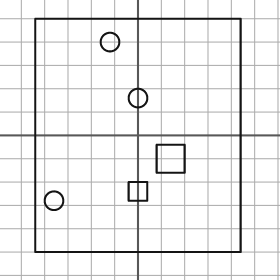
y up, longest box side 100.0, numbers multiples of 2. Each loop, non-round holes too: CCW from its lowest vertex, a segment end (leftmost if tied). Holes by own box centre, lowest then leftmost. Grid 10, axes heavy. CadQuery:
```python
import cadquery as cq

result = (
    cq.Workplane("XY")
    .moveTo(-44.0, -50.0)
    .lineTo(44.0, -50.0)
    .lineTo(44.0, 50.0)
    .lineTo(-44.0, 50.0)
    .close()
    .moveTo(-36.0, -28.0)
    .circle(4.0)
    .moveTo(-4.0, -28.0)
    .lineTo(4.0, -28.0)
    .lineTo(4.0, -20.0)
    .lineTo(-4.0, -20.0)
    .close()
    .moveTo(8.0, -16.0)
    .lineTo(20.0, -16.0)
    .lineTo(20.0, -4.0)
    .lineTo(8.0, -4.0)
    .close()
    .moveTo(0.0, 16.0)
    .circle(4.0)
    .moveTo(-12.0, 40.0)
    .circle(4.0)
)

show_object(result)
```